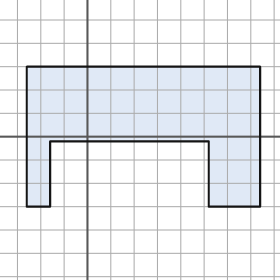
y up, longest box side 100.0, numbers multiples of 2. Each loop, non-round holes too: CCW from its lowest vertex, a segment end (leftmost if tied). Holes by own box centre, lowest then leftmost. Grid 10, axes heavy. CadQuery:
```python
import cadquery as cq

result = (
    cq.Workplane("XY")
    .moveTo(-26.0, -30.0)
    .lineTo(-16.0, -30.0)
    .lineTo(-16.0, -2.0)
    .lineTo(52.0, -2.0)
    .lineTo(52.0, -30.0)
    .lineTo(74.0, -30.0)
    .lineTo(74.0, 30.0)
    .lineTo(-26.0, 30.0)
    .close()
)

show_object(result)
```